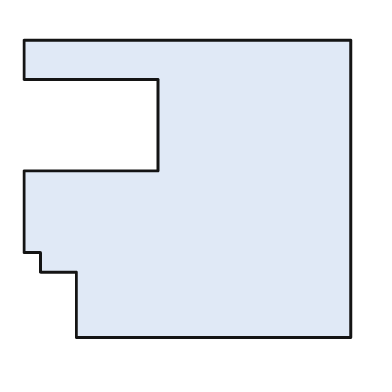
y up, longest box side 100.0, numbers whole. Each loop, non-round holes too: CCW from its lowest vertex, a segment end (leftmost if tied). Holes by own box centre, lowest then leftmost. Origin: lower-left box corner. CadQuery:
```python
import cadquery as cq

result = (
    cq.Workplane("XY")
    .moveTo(16.0, 0.0)
    .lineTo(100.0, 0.0)
    .lineTo(100.0, 91.0)
    .lineTo(0.0, 91.0)
    .lineTo(0.0, 79.0)
    .lineTo(41.0, 79.0)
    .lineTo(41.0, 51.0)
    .lineTo(0.0, 51.0)
    .lineTo(0.0, 26.0)
    .lineTo(5.0, 26.0)
    .lineTo(5.0, 20.0)
    .lineTo(16.0, 20.0)
    .close()
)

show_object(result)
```